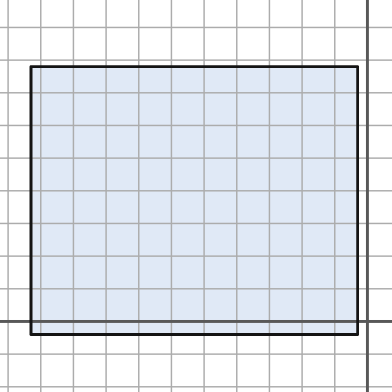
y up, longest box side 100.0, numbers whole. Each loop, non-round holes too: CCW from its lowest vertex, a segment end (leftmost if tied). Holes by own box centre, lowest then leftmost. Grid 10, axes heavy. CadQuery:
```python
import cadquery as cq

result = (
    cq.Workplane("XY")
    .moveTo(-103.0, -4.0)
    .lineTo(-3.0, -4.0)
    .lineTo(-3.0, 78.0)
    .lineTo(-103.0, 78.0)
    .close()
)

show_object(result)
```